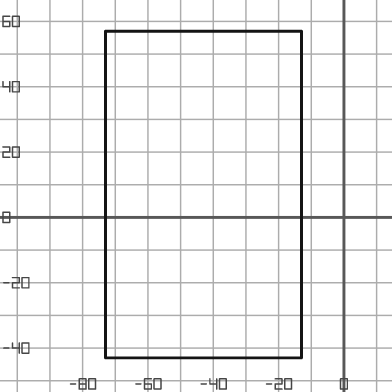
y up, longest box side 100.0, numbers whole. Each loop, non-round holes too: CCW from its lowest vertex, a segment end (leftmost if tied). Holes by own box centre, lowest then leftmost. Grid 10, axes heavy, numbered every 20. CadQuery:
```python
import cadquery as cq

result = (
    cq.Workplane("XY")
    .moveTo(-73.0, -43.0)
    .lineTo(-13.0, -43.0)
    .lineTo(-13.0, 57.0)
    .lineTo(-73.0, 57.0)
    .close()
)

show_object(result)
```